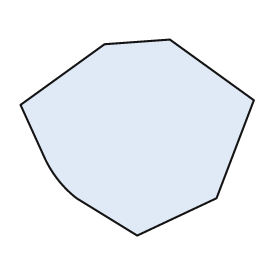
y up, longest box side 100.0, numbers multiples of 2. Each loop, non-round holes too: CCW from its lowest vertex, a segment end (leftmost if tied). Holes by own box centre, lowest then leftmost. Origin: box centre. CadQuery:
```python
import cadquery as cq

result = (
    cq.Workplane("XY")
    .moveTo(0.0, -42.0)
    .lineTo(34.0, -26.0)
    .lineTo(50.0, 16.0)
    .lineTo(14.0, 42.0)
    .lineTo(-14.0, 40.0)
    .lineTo(-50.0, 14.0)
    .lineTo(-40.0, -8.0)
    .threePointArc((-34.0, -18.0), (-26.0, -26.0))
    .close()
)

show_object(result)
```